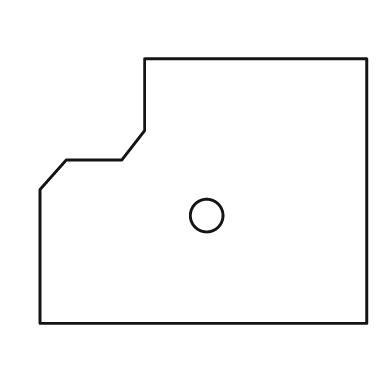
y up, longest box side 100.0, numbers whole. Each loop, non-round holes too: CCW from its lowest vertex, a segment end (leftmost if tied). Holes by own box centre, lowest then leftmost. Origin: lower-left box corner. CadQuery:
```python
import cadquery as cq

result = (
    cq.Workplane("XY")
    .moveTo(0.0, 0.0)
    .lineTo(100.0, 0.0)
    .lineTo(100.0, 81.0)
    .lineTo(32.0, 81.0)
    .lineTo(32.0, 59.0)
    .lineTo(25.0, 50.0)
    .lineTo(8.0, 50.0)
    .lineTo(0.0, 41.0)
    .close()
    .moveTo(51.0, 33.0)
    .circle(5.0)
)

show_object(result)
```